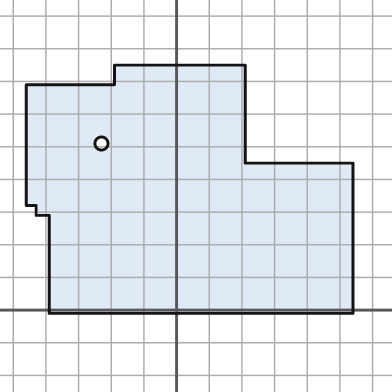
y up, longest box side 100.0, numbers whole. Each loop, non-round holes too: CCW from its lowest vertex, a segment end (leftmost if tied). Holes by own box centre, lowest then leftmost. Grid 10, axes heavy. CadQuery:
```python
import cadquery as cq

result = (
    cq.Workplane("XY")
    .moveTo(-39.0, -1.0)
    .lineTo(54.0, -1.0)
    .lineTo(54.0, 45.0)
    .lineTo(21.0, 45.0)
    .lineTo(21.0, 75.0)
    .lineTo(-19.0, 75.0)
    .lineTo(-19.0, 69.0)
    .lineTo(-46.0, 69.0)
    .lineTo(-46.0, 32.0)
    .lineTo(-43.0, 32.0)
    .lineTo(-43.0, 29.0)
    .lineTo(-39.0, 29.0)
    .close()
    .moveTo(-23.0, 51.0)
    .circle(2.0)
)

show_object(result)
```